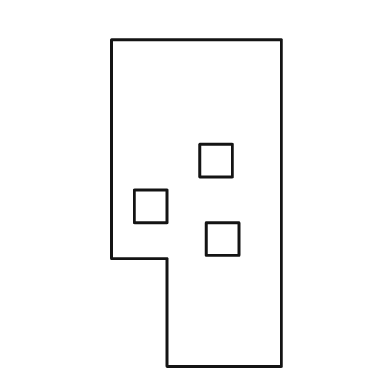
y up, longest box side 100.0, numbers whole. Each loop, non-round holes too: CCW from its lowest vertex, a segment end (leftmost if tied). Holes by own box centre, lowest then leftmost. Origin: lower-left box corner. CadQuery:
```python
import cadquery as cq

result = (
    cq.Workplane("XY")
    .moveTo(17.0, 0.0)
    .lineTo(52.0, 0.0)
    .lineTo(52.0, 100.0)
    .lineTo(0.0, 100.0)
    .lineTo(0.0, 33.0)
    .lineTo(17.0, 33.0)
    .close()
    .moveTo(29.0, 34.0)
    .lineTo(39.0, 34.0)
    .lineTo(39.0, 44.0)
    .lineTo(29.0, 44.0)
    .close()
    .moveTo(7.0, 44.0)
    .lineTo(17.0, 44.0)
    .lineTo(17.0, 54.0)
    .lineTo(7.0, 54.0)
    .close()
    .moveTo(27.0, 58.0)
    .lineTo(37.0, 58.0)
    .lineTo(37.0, 68.0)
    .lineTo(27.0, 68.0)
    .close()
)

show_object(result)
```